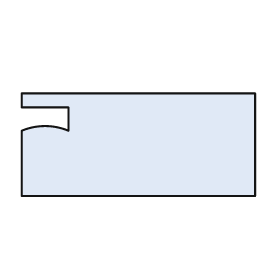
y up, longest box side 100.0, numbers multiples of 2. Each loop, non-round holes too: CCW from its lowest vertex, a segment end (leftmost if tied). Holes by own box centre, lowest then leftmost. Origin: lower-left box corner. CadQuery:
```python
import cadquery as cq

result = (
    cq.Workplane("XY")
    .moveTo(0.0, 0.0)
    .lineTo(100.0, 0.0)
    .lineTo(100.0, 44.0)
    .lineTo(0.0, 44.0)
    .lineTo(0.0, 38.0)
    .lineTo(20.0, 38.0)
    .lineTo(20.0, 28.0)
    .threePointArc((10.0, 30.0), (0.0, 28.0))
    .close()
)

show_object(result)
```